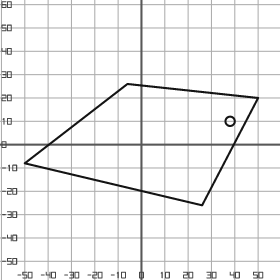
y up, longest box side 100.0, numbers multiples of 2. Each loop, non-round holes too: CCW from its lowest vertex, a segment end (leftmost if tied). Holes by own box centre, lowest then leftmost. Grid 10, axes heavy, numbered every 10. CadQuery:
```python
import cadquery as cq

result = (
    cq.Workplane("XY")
    .moveTo(26.0, -26.0)
    .lineTo(50.0, 20.0)
    .lineTo(-6.0, 26.0)
    .lineTo(-50.0, -8.0)
    .close()
    .moveTo(38.0, 10.0)
    .circle(2.0)
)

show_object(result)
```